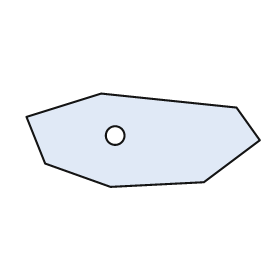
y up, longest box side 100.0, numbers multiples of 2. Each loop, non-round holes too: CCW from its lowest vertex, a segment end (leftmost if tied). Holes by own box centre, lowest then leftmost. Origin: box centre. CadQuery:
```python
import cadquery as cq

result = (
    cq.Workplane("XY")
    .moveTo(-14.0, -20.0)
    .lineTo(26.0, -18.0)
    .lineTo(50.0, 0.0)
    .lineTo(40.0, 14.0)
    .lineTo(-18.0, 20.0)
    .lineTo(-50.0, 10.0)
    .lineTo(-42.0, -10.0)
    .close()
    .moveTo(-12.0, 2.0)
    .circle(4.0)
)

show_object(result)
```